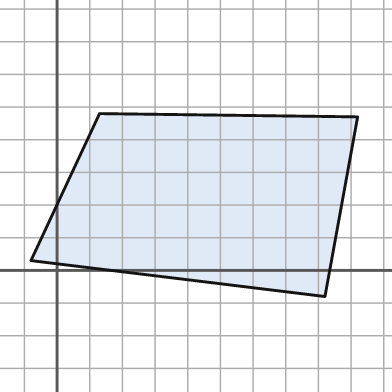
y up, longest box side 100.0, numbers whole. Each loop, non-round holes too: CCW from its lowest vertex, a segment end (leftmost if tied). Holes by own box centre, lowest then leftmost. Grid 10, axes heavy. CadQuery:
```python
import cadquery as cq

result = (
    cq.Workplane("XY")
    .moveTo(82.0, -8.0)
    .lineTo(92.0, 47.0)
    .lineTo(13.0, 48.0)
    .lineTo(-8.0, 3.0)
    .close()
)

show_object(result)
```